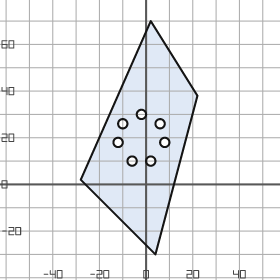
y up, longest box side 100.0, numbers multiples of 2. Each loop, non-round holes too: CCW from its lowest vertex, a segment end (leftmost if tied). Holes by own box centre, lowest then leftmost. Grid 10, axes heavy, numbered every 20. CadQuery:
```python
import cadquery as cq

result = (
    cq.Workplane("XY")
    .moveTo(4.0, -30.0)
    .lineTo(22.0, 38.0)
    .lineTo(2.0, 70.0)
    .lineTo(-28.0, 2.0)
    .close()
    .moveTo(-6.0, 10.0)
    .circle(2.0)
    .moveTo(2.0, 10.0)
    .circle(2.0)
    .moveTo(-12.0, 18.0)
    .circle(2.0)
    .moveTo(8.0, 18.0)
    .circle(2.0)
    .moveTo(-10.0, 26.0)
    .circle(2.0)
    .moveTo(6.0, 26.0)
    .circle(2.0)
    .moveTo(-2.0, 30.0)
    .circle(2.0)
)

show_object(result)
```